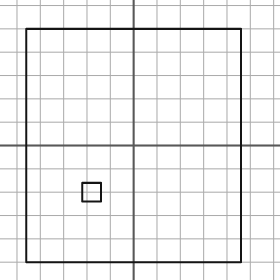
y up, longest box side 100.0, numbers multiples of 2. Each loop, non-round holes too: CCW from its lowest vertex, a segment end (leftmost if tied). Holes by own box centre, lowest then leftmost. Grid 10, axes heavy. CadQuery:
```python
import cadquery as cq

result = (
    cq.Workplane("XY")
    .moveTo(-46.0, -50.0)
    .lineTo(46.0, -50.0)
    .lineTo(46.0, 50.0)
    .lineTo(-46.0, 50.0)
    .close()
    .moveTo(-22.0, -24.0)
    .lineTo(-14.0, -24.0)
    .lineTo(-14.0, -16.0)
    .lineTo(-22.0, -16.0)
    .close()
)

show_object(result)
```